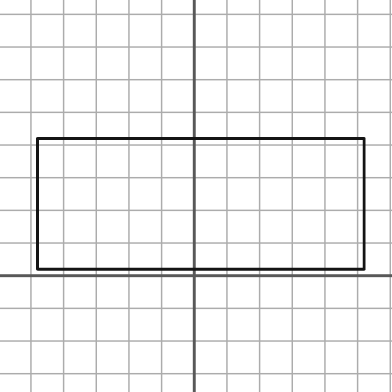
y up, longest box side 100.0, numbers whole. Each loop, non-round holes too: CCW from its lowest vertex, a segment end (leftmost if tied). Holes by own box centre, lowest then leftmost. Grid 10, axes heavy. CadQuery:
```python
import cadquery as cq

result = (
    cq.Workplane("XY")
    .moveTo(-48.0, 2.0)
    .lineTo(52.0, 2.0)
    .lineTo(52.0, 42.0)
    .lineTo(-48.0, 42.0)
    .close()
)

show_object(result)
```